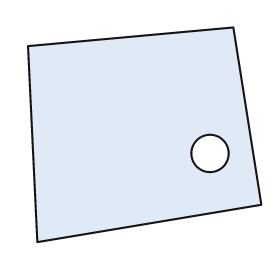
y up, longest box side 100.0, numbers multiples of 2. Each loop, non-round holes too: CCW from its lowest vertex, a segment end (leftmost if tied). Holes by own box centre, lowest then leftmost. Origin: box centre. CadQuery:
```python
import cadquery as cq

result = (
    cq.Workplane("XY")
    .moveTo(-46.0, -46.0)
    .lineTo(50.0, -30.0)
    .lineTo(38.0, 46.0)
    .lineTo(-50.0, 38.0)
    .close()
    .moveTo(28.0, -8.0)
    .circle(8.0)
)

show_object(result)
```